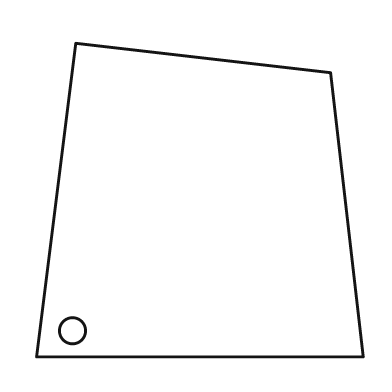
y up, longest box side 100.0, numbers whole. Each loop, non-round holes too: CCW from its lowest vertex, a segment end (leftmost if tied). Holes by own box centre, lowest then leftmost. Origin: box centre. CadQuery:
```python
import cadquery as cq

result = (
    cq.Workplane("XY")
    .moveTo(-50.0, -48.0)
    .lineTo(50.0, -48.0)
    .lineTo(40.0, 39.0)
    .lineTo(-38.0, 48.0)
    .close()
    .moveTo(-39.0, -40.0)
    .circle(4.0)
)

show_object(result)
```